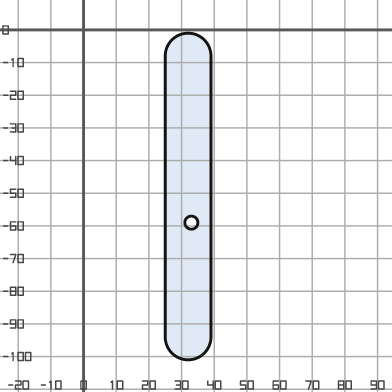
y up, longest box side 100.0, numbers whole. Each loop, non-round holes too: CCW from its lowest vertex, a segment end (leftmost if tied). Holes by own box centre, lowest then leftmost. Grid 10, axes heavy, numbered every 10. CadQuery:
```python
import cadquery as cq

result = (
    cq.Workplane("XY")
    .moveTo(25.0, -94.0)
    .threePointArc((32.0, -101.0), (39.0, -94.0))
    .lineTo(39.0, -8.0)
    .threePointArc((32.0, -1.0), (25.0, -8.0))
    .close()
    .moveTo(33.0, -59.0)
    .circle(2.0)
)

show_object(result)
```